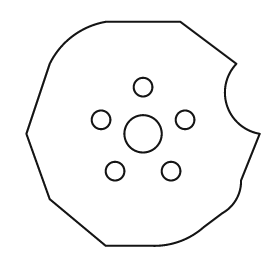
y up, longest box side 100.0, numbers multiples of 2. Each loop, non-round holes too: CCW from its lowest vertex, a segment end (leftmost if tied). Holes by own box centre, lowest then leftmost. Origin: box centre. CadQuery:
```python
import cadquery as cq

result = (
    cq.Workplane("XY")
    .moveTo(-16.0, -48.0)
    .lineTo(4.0, -48.0)
    .threePointArc((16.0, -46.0), (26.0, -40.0))
    .lineTo(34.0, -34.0)
    .threePointArc((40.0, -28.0), (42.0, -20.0))
    .lineTo(50.0, 0.0)
    .threePointArc((36.0, 12.0), (40.0, 30.0))
    .lineTo(16.0, 48.0)
    .lineTo(-16.0, 48.0)
    .threePointArc((-30.0, 42.0), (-40.0, 30.0))
    .lineTo(-50.0, 0.0)
    .lineTo(-40.0, -28.0)
    .close()
    .moveTo(-12.0, -16.0)
    .circle(4.0)
    .moveTo(12.0, -16.0)
    .circle(4.0)
    .moveTo(0.0, 0.0)
    .circle(8.0)
    .moveTo(-18.0, 6.0)
    .circle(4.0)
    .moveTo(18.0, 6.0)
    .circle(4.0)
    .moveTo(0.0, 20.0)
    .circle(4.0)
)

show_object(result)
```